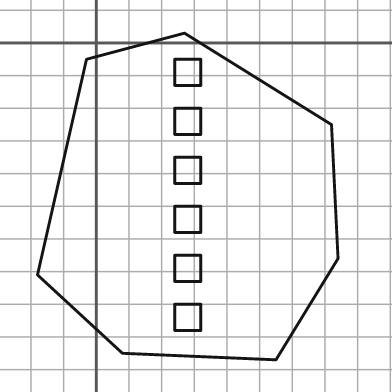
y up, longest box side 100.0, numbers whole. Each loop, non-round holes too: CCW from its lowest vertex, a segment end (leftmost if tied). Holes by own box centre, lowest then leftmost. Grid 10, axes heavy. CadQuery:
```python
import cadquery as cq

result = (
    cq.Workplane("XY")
    .moveTo(55.0, -97.0)
    .lineTo(74.0, -66.0)
    .lineTo(72.0, -25.0)
    .lineTo(27.0, 3.0)
    .lineTo(-3.0, -5.0)
    .lineTo(-18.0, -71.0)
    .lineTo(8.0, -95.0)
    .close()
    .moveTo(24.0, -88.0)
    .lineTo(32.0, -88.0)
    .lineTo(32.0, -80.0)
    .lineTo(24.0, -80.0)
    .close()
    .moveTo(24.0, -73.0)
    .lineTo(32.0, -73.0)
    .lineTo(32.0, -65.0)
    .lineTo(24.0, -65.0)
    .close()
    .moveTo(24.0, -58.0)
    .lineTo(32.0, -58.0)
    .lineTo(32.0, -50.0)
    .lineTo(24.0, -50.0)
    .close()
    .moveTo(24.0, -43.0)
    .lineTo(32.0, -43.0)
    .lineTo(32.0, -35.0)
    .lineTo(24.0, -35.0)
    .close()
    .moveTo(24.0, -28.0)
    .lineTo(32.0, -28.0)
    .lineTo(32.0, -20.0)
    .lineTo(24.0, -20.0)
    .close()
    .moveTo(24.0, -13.0)
    .lineTo(32.0, -13.0)
    .lineTo(32.0, -5.0)
    .lineTo(24.0, -5.0)
    .close()
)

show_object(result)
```